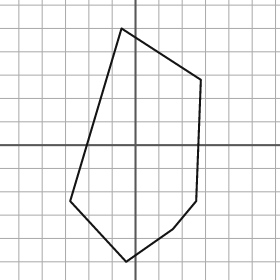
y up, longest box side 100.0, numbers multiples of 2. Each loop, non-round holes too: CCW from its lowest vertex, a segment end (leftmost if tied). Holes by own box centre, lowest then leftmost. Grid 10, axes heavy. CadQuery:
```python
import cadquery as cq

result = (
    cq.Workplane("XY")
    .moveTo(-4.0, -50.0)
    .lineTo(16.0, -36.0)
    .lineTo(26.0, -24.0)
    .lineTo(28.0, 28.0)
    .lineTo(-6.0, 50.0)
    .lineTo(-28.0, -24.0)
    .close()
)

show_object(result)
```